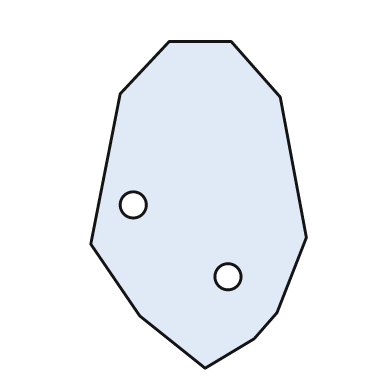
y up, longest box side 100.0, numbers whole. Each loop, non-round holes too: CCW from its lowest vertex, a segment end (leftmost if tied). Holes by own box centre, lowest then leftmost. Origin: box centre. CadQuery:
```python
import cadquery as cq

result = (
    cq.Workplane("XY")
    .moveTo(2.0, -50.0)
    .lineTo(17.0, -41.0)
    .lineTo(24.0, -33.0)
    .lineTo(33.0, -10.0)
    .lineTo(25.0, 33.0)
    .lineTo(10.0, 50.0)
    .lineTo(-9.0, 50.0)
    .lineTo(-24.0, 34.0)
    .lineTo(-33.0, -12.0)
    .lineTo(-18.0, -34.0)
    .close()
    .moveTo(9.0, -22.0)
    .circle(4.0)
    .moveTo(-20.0, 0.0)
    .circle(4.0)
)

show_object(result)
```